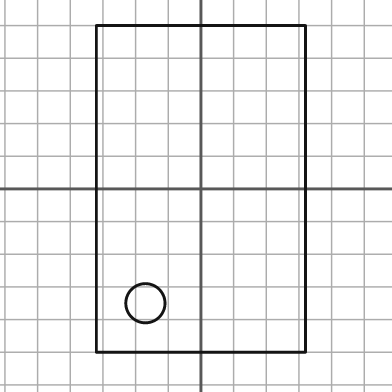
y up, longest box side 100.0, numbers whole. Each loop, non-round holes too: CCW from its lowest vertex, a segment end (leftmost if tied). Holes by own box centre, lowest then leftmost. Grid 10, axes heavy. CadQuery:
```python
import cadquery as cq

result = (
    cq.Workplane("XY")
    .moveTo(-32.0, -50.0)
    .lineTo(32.0, -50.0)
    .lineTo(32.0, 50.0)
    .lineTo(-32.0, 50.0)
    .close()
    .moveTo(-17.0, -35.0)
    .circle(6.0)
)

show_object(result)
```